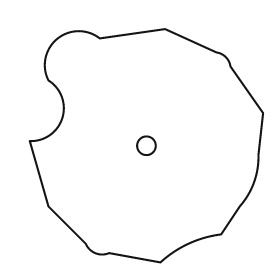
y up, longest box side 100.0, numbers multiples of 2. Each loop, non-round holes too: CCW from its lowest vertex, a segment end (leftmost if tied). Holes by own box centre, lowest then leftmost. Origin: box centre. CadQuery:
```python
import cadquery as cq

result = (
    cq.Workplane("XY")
    .moveTo(6.0, -50.0)
    .threePointArc((18.0, -42.0), (32.0, -38.0))
    .lineTo(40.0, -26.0)
    .threePointArc((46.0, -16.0), (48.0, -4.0))
    .lineTo(50.0, 14.0)
    .lineTo(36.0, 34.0)
    .threePointArc((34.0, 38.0), (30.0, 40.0))
    .lineTo(8.0, 50.0)
    .lineTo(-20.0, 46.0)
    .threePointArc((-38.0, 46.0), (-42.0, 28.0))
    .threePointArc((-36.0, 12.0), (-50.0, 2.0))
    .lineTo(-42.0, -26.0)
    .lineTo(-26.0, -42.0)
    .threePointArc((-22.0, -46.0), (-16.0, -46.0))
    .close()
    .moveTo(0.0, 0.0)
    .circle(4.0)
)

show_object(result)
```